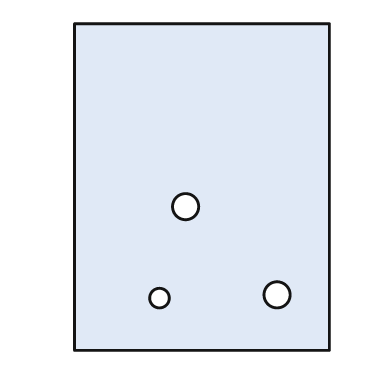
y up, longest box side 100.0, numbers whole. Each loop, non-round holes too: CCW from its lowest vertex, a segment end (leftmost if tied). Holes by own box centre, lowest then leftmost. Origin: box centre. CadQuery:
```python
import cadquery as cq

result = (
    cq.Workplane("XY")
    .moveTo(-39.0, -50.0)
    .lineTo(39.0, -50.0)
    .lineTo(39.0, 50.0)
    .lineTo(-39.0, 50.0)
    .close()
    .moveTo(-13.0, -34.0)
    .circle(3.0)
    .moveTo(23.0, -33.0)
    .circle(4.0)
    .moveTo(-5.0, -6.0)
    .circle(4.0)
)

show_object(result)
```